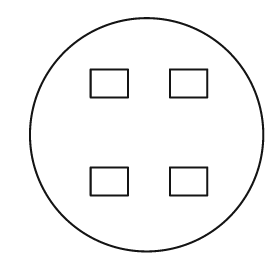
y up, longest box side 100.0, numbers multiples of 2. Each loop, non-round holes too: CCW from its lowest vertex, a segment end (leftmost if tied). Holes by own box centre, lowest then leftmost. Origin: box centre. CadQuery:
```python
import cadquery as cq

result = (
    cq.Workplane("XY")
    .moveTo(0.0, 0.0)
    .circle(50.0)
    .moveTo(-24.0, -26.0)
    .lineTo(-8.0, -26.0)
    .lineTo(-8.0, -14.0)
    .lineTo(-24.0, -14.0)
    .close()
    .moveTo(10.0, -26.0)
    .lineTo(26.0, -26.0)
    .lineTo(26.0, -14.0)
    .lineTo(10.0, -14.0)
    .close()
    .moveTo(-24.0, 16.0)
    .lineTo(-8.0, 16.0)
    .lineTo(-8.0, 28.0)
    .lineTo(-24.0, 28.0)
    .close()
    .moveTo(10.0, 16.0)
    .lineTo(26.0, 16.0)
    .lineTo(26.0, 28.0)
    .lineTo(10.0, 28.0)
    .close()
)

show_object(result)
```